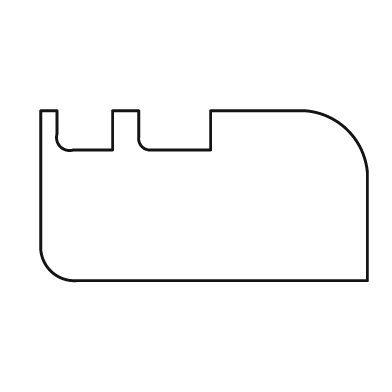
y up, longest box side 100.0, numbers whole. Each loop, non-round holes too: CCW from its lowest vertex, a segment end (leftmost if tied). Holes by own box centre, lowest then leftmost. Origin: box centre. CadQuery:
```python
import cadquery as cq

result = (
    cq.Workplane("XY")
    .moveTo(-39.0, -26.0)
    .lineTo(50.0, -26.0)
    .lineTo(50.0, 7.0)
    .threePointArc((44.0, 20.0), (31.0, 26.0))
    .lineTo(2.0, 26.0)
    .lineTo(2.0, 14.0)
    .lineTo(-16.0, 14.0)
    .threePointArc((-19.0, 15.0), (-20.0, 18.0))
    .lineTo(-20.0, 26.0)
    .lineTo(-28.0, 26.0)
    .lineTo(-28.0, 14.0)
    .lineTo(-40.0, 14.0)
    .threePointArc((-44.0, 15.0), (-45.0, 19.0))
    .lineTo(-45.0, 26.0)
    .lineTo(-50.0, 26.0)
    .lineTo(-50.0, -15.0)
    .threePointArc((-47.0, -23.0), (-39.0, -26.0))
    .close()
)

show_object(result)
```